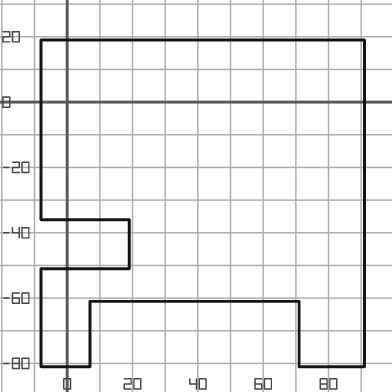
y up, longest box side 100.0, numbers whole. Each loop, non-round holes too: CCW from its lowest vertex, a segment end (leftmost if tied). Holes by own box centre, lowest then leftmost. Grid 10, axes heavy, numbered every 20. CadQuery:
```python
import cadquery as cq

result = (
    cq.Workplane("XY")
    .moveTo(-8.0, -81.0)
    .lineTo(7.0, -81.0)
    .lineTo(7.0, -61.0)
    .lineTo(71.0, -61.0)
    .lineTo(71.0, -81.0)
    .lineTo(91.0, -81.0)
    .lineTo(91.0, 19.0)
    .lineTo(-8.0, 19.0)
    .lineTo(-8.0, -36.0)
    .lineTo(19.0, -36.0)
    .lineTo(19.0, -51.0)
    .lineTo(-8.0, -51.0)
    .close()
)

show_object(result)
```